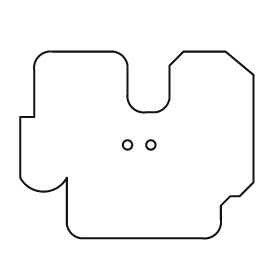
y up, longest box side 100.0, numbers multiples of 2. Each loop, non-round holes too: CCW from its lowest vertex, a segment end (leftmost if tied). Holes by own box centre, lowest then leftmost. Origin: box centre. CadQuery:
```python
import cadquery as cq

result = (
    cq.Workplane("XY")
    .moveTo(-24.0, -40.0)
    .lineTo(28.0, -40.0)
    .threePointArc((34.0, -38.0), (36.0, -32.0))
    .lineTo(36.0, -26.0)
    .lineTo(40.0, -22.0)
    .lineTo(44.0, -22.0)
    .lineTo(50.0, -16.0)
    .lineTo(50.0, 30.0)
    .lineTo(38.0, 40.0)
    .lineTo(20.0, 40.0)
    .lineTo(14.0, 34.0)
    .lineTo(14.0, 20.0)
    .threePointArc((12.0, 16.0), (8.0, 14.0))
    .lineTo(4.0, 14.0)
    .threePointArc((-2.0, 16.0), (-4.0, 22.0))
    .lineTo(-4.0, 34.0)
    .threePointArc((-6.0, 38.0), (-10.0, 40.0))
    .lineTo(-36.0, 40.0)
    .threePointArc((-42.0, 38.0), (-44.0, 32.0))
    .lineTo(-44.0, 12.0)
    .lineTo(-50.0, 12.0)
    .lineTo(-50.0, -14.0)
    .threePointArc((-40.0, -20.0), (-30.0, -14.0))
    .lineTo(-30.0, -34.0)
    .threePointArc((-28.0, -38.0), (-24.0, -40.0))
    .close()
    .moveTo(-4.0, 0.0)
    .circle(2.0)
    .moveTo(6.0, 0.0)
    .circle(2.0)
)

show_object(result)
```